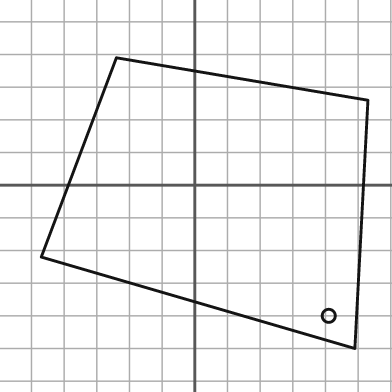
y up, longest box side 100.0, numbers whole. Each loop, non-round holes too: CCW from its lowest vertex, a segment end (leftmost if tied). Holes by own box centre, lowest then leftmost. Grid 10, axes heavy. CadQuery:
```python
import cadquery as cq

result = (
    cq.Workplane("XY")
    .moveTo(49.0, -50.0)
    .lineTo(53.0, 26.0)
    .lineTo(-24.0, 39.0)
    .lineTo(-47.0, -22.0)
    .close()
    .moveTo(41.0, -40.0)
    .circle(2.0)
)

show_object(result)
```